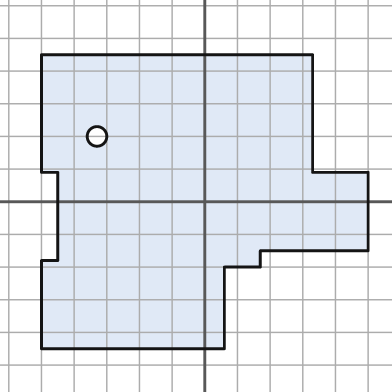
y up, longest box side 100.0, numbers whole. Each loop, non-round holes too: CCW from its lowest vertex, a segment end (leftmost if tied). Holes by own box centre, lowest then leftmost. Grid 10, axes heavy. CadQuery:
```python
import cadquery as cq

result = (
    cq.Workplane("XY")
    .moveTo(-50.0, -45.0)
    .lineTo(6.0, -45.0)
    .lineTo(6.0, -20.0)
    .lineTo(17.0, -20.0)
    .lineTo(17.0, -15.0)
    .lineTo(50.0, -15.0)
    .lineTo(50.0, 9.0)
    .lineTo(33.0, 9.0)
    .lineTo(33.0, 45.0)
    .lineTo(-50.0, 45.0)
    .lineTo(-50.0, 9.0)
    .lineTo(-45.0, 9.0)
    .lineTo(-45.0, -18.0)
    .lineTo(-50.0, -18.0)
    .close()
    .moveTo(-33.0, 20.0)
    .circle(3.0)
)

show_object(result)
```